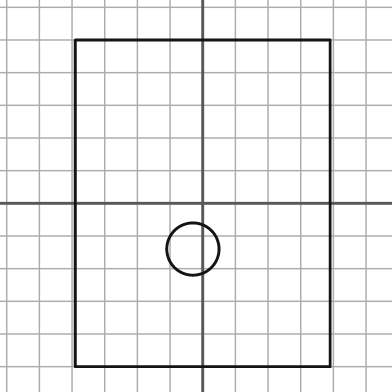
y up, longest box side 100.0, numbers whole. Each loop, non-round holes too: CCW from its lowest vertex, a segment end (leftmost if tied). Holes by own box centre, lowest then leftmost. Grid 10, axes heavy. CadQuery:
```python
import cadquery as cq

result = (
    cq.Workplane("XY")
    .moveTo(-39.0, -50.0)
    .lineTo(39.0, -50.0)
    .lineTo(39.0, 50.0)
    .lineTo(-39.0, 50.0)
    .close()
    .moveTo(-3.0, -14.0)
    .circle(8.0)
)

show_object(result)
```